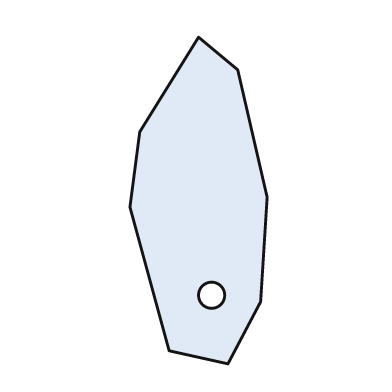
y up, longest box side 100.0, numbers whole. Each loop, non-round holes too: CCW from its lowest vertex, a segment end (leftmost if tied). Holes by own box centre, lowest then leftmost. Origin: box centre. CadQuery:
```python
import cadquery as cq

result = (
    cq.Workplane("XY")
    .moveTo(9.0, -50.0)
    .lineTo(19.0, -31.0)
    .lineTo(21.0, 1.0)
    .lineTo(12.0, 40.0)
    .lineTo(0.0, 50.0)
    .lineTo(-18.0, 21.0)
    .lineTo(-21.0, -2.0)
    .lineTo(-9.0, -46.0)
    .close()
    .moveTo(4.0, -29.0)
    .circle(4.0)
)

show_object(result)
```